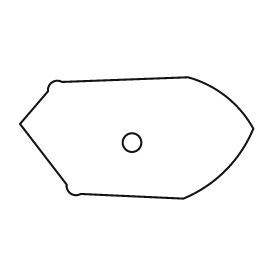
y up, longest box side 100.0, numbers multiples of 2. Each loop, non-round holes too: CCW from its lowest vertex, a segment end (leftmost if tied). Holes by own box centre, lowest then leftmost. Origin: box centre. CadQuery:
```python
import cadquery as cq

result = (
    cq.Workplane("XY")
    .moveTo(20.0, -26.0)
    .threePointArc((38.0, -14.0), (50.0, 4.0))
    .threePointArc((38.0, 18.0), (22.0, 26.0))
    .lineTo(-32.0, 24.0)
    .threePointArc((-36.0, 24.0), (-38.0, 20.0))
    .lineTo(-50.0, 6.0)
    .lineTo(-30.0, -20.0)
    .threePointArc((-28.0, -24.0), (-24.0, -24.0))
    .close()
    .moveTo(-2.0, -2.0)
    .circle(4.0)
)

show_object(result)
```